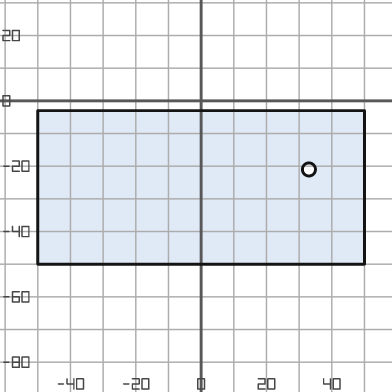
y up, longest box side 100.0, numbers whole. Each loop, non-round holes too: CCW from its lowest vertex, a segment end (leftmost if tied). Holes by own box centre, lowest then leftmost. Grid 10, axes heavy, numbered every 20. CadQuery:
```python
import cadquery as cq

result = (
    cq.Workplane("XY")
    .moveTo(-50.0, -50.0)
    .lineTo(50.0, -50.0)
    .lineTo(50.0, -3.0)
    .lineTo(-50.0, -3.0)
    .close()
    .moveTo(33.0, -21.0)
    .circle(2.0)
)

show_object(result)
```